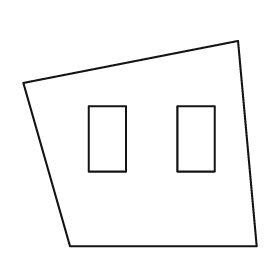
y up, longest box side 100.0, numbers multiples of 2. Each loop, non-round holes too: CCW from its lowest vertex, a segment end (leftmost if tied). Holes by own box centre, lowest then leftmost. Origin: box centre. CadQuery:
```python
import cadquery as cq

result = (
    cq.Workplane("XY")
    .moveTo(-30.0, -44.0)
    .lineTo(50.0, -44.0)
    .lineTo(42.0, 44.0)
    .lineTo(-50.0, 26.0)
    .close()
    .moveTo(-22.0, -12.0)
    .lineTo(-6.0, -12.0)
    .lineTo(-6.0, 16.0)
    .lineTo(-22.0, 16.0)
    .close()
    .moveTo(16.0, -12.0)
    .lineTo(32.0, -12.0)
    .lineTo(32.0, 16.0)
    .lineTo(16.0, 16.0)
    .close()
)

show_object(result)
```